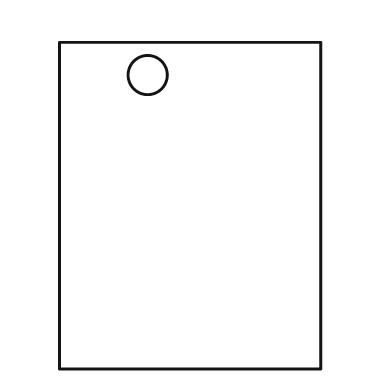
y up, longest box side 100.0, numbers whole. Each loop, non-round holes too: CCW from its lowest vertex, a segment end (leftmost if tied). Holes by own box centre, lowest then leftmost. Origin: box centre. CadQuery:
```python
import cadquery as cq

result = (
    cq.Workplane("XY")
    .moveTo(-40.0, -50.0)
    .lineTo(40.0, -50.0)
    .lineTo(40.0, 50.0)
    .lineTo(-40.0, 50.0)
    .close()
    .moveTo(-13.0, 40.0)
    .circle(6.0)
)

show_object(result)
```